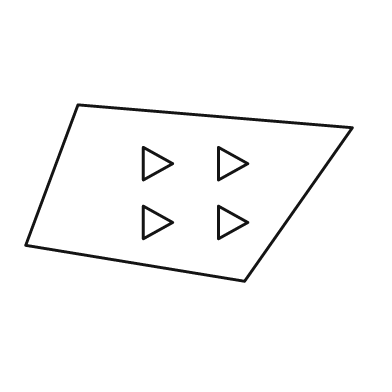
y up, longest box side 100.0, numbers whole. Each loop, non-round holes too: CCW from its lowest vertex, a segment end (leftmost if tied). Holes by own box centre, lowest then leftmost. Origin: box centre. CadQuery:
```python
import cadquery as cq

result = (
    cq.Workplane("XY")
    .moveTo(17.0, -27.0)
    .lineTo(50.0, 20.0)
    .lineTo(-34.0, 27.0)
    .lineTo(-50.0, -16.0)
    .close()
    .moveTo(-14.0, -14.0)
    .lineTo(-5.0, -9.0)
    .lineTo(-14.0, -4.0)
    .close()
    .moveTo(9.0, -14.0)
    .lineTo(18.0, -9.0)
    .lineTo(9.0, -4.0)
    .close()
    .moveTo(-14.0, 4.0)
    .lineTo(-5.0, 9.0)
    .lineTo(-14.0, 14.0)
    .close()
    .moveTo(9.0, 4.0)
    .lineTo(18.0, 9.0)
    .lineTo(9.0, 14.0)
    .close()
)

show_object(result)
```